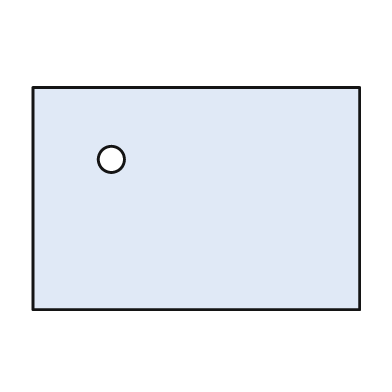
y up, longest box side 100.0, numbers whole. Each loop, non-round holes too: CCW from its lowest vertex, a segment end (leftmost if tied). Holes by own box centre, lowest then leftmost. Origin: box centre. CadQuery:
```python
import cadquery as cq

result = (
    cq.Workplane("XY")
    .moveTo(-50.0, -34.0)
    .lineTo(50.0, -34.0)
    .lineTo(50.0, 34.0)
    .lineTo(-50.0, 34.0)
    .close()
    .moveTo(-26.0, 12.0)
    .circle(4.0)
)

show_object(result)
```